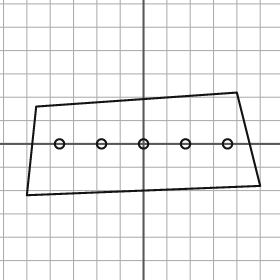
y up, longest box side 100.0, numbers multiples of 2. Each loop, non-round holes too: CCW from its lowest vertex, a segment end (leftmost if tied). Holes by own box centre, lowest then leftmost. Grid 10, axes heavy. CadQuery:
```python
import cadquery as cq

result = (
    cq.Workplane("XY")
    .moveTo(-50.0, -22.0)
    .lineTo(50.0, -18.0)
    .lineTo(40.0, 22.0)
    .lineTo(-46.0, 16.0)
    .close()
    .moveTo(-36.0, 0.0)
    .circle(2.0)
    .moveTo(-18.0, 0.0)
    .circle(2.0)
    .moveTo(0.0, 0.0)
    .circle(2.0)
    .moveTo(18.0, 0.0)
    .circle(2.0)
    .moveTo(36.0, 0.0)
    .circle(2.0)
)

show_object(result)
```